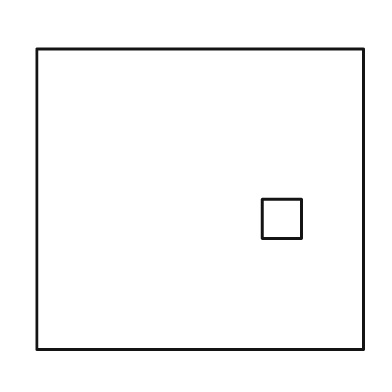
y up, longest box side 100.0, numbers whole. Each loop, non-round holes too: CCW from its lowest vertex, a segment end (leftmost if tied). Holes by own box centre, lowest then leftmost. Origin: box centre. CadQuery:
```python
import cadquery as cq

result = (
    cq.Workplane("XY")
    .moveTo(-50.0, -46.0)
    .lineTo(50.0, -46.0)
    .lineTo(50.0, 46.0)
    .lineTo(-50.0, 46.0)
    .close()
    .moveTo(19.0, -12.0)
    .lineTo(31.0, -12.0)
    .lineTo(31.0, 0.0)
    .lineTo(19.0, 0.0)
    .close()
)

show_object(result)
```